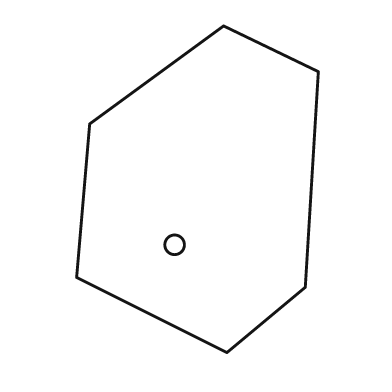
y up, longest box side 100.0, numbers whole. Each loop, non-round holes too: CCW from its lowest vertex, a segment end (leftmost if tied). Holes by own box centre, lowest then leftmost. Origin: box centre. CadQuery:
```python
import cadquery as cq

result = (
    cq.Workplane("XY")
    .moveTo(9.0, -50.0)
    .lineTo(33.0, -30.0)
    .lineTo(37.0, 36.0)
    .lineTo(8.0, 50.0)
    .lineTo(-33.0, 20.0)
    .lineTo(-37.0, -27.0)
    .close()
    .moveTo(-7.0, -17.0)
    .circle(3.0)
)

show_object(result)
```